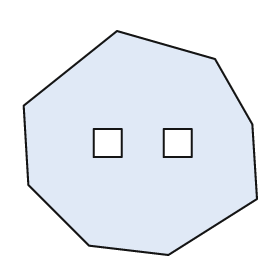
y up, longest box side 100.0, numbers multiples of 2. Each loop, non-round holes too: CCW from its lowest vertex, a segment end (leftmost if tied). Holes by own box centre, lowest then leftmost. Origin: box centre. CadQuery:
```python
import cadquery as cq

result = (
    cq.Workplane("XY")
    .moveTo(12.0, -48.0)
    .lineTo(50.0, -24.0)
    .lineTo(48.0, 8.0)
    .lineTo(32.0, 36.0)
    .lineTo(-10.0, 48.0)
    .lineTo(-50.0, 16.0)
    .lineTo(-48.0, -18.0)
    .lineTo(-22.0, -44.0)
    .close()
    .moveTo(-20.0, -6.0)
    .lineTo(-8.0, -6.0)
    .lineTo(-8.0, 6.0)
    .lineTo(-20.0, 6.0)
    .close()
    .moveTo(10.0, -6.0)
    .lineTo(22.0, -6.0)
    .lineTo(22.0, 6.0)
    .lineTo(10.0, 6.0)
    .close()
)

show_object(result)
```